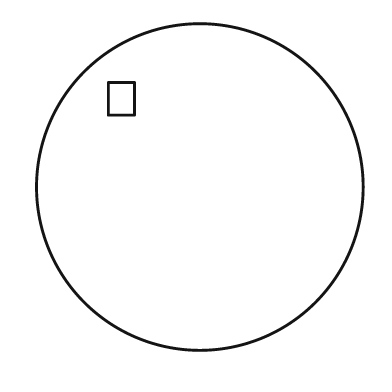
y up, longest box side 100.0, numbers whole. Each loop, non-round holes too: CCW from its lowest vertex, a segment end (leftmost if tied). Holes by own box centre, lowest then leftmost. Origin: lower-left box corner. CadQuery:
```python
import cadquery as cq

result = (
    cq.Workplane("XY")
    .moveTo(50.0, 50.0)
    .circle(50.0)
    .moveTo(22.0, 72.0)
    .lineTo(30.0, 72.0)
    .lineTo(30.0, 82.0)
    .lineTo(22.0, 82.0)
    .close()
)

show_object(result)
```